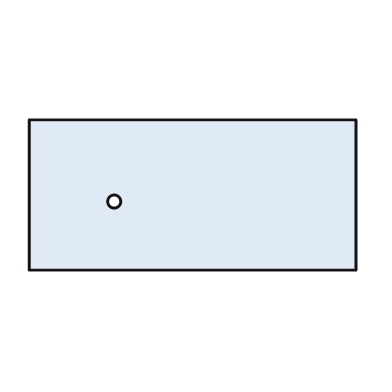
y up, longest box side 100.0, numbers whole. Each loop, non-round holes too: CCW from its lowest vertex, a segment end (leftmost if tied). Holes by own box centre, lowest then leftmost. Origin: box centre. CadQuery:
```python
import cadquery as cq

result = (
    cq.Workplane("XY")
    .moveTo(-50.0, -23.0)
    .lineTo(50.0, -23.0)
    .lineTo(50.0, 23.0)
    .lineTo(-50.0, 23.0)
    .close()
    .moveTo(-24.0, -2.0)
    .circle(2.0)
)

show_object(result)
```